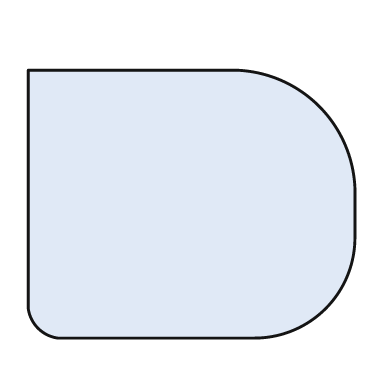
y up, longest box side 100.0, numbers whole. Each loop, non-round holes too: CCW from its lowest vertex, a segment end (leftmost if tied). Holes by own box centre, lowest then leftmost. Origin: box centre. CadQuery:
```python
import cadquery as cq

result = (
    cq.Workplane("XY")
    .moveTo(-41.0, -41.0)
    .lineTo(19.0, -41.0)
    .threePointArc((41.0, -32.0), (50.0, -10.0))
    .lineTo(50.0, 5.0)
    .threePointArc((39.0, 30.0), (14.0, 41.0))
    .lineTo(-50.0, 41.0)
    .lineTo(-50.0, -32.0)
    .threePointArc((-47.0, -38.0), (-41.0, -41.0))
    .close()
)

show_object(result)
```